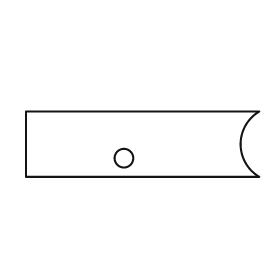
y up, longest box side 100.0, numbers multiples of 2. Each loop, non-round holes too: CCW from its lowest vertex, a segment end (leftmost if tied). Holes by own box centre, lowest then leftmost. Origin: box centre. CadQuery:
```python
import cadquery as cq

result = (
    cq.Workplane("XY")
    .moveTo(-50.0, -14.0)
    .lineTo(50.0, -14.0)
    .threePointArc((42.0, 0.0), (50.0, 14.0))
    .lineTo(-50.0, 14.0)
    .close()
    .moveTo(-8.0, -6.0)
    .circle(4.0)
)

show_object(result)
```